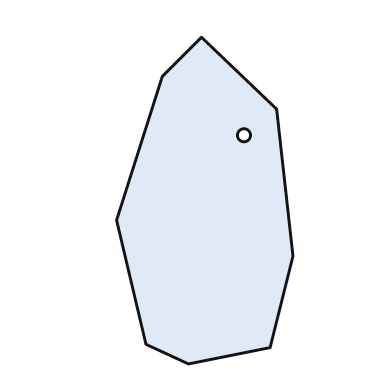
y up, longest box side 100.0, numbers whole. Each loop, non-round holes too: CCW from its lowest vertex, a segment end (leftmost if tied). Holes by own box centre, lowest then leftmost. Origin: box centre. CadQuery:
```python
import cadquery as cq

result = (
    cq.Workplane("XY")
    .moveTo(-5.0, -50.0)
    .lineTo(20.0, -45.0)
    .lineTo(27.0, -17.0)
    .lineTo(22.0, 28.0)
    .lineTo(-1.0, 50.0)
    .lineTo(-13.0, 38.0)
    .lineTo(-27.0, -6.0)
    .lineTo(-18.0, -44.0)
    .close()
    .moveTo(12.0, 20.0)
    .circle(2.0)
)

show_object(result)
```